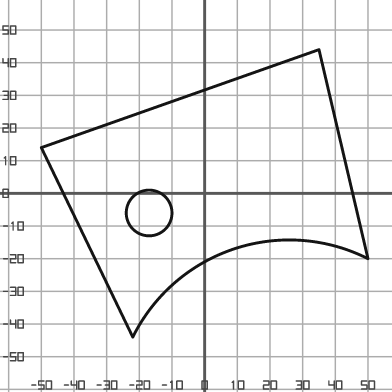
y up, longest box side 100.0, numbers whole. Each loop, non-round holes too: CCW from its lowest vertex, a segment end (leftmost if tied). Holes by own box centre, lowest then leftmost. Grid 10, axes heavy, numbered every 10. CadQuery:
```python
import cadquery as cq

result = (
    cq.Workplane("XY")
    .moveTo(-22.0, -44.0)
    .threePointArc((9.0, -17.0), (50.0, -20.0))
    .lineTo(35.0, 44.0)
    .lineTo(-50.0, 14.0)
    .close()
    .moveTo(-17.0, -6.0)
    .circle(7.0)
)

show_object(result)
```